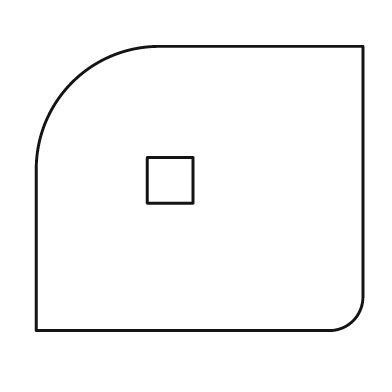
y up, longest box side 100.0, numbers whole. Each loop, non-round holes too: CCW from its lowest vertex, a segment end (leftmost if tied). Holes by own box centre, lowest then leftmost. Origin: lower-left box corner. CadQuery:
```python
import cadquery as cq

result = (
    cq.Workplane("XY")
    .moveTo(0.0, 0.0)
    .lineTo(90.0, 0.0)
    .threePointArc((97.0, 3.0), (100.0, 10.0))
    .lineTo(100.0, 87.0)
    .lineTo(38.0, 87.0)
    .threePointArc((11.0, 76.0), (0.0, 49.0))
    .close()
    .moveTo(34.0, 39.0)
    .lineTo(48.0, 39.0)
    .lineTo(48.0, 53.0)
    .lineTo(34.0, 53.0)
    .close()
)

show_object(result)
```